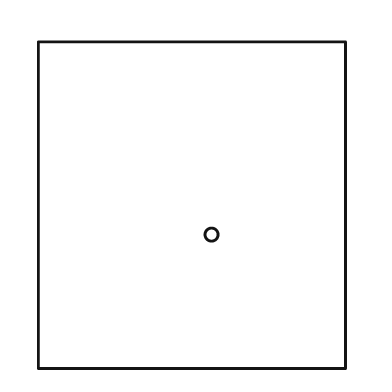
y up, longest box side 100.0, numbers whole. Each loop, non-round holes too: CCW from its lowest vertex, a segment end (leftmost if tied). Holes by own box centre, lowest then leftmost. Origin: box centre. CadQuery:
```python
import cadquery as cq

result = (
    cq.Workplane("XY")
    .moveTo(-47.0, -50.0)
    .lineTo(47.0, -50.0)
    .lineTo(47.0, 50.0)
    .lineTo(-47.0, 50.0)
    .close()
    .moveTo(6.0, -9.0)
    .circle(2.0)
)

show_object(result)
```